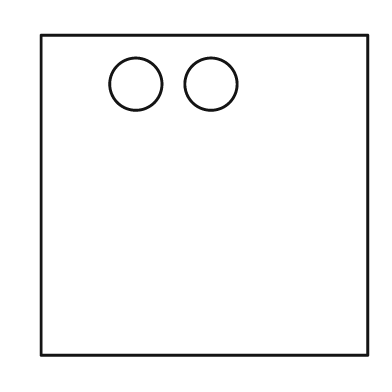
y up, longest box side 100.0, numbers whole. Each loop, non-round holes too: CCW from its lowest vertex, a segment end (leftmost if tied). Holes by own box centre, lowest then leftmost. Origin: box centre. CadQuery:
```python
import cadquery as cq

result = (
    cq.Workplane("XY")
    .moveTo(-50.0, -49.0)
    .lineTo(50.0, -49.0)
    .lineTo(50.0, 49.0)
    .lineTo(-50.0, 49.0)
    .close()
    .moveTo(-21.0, 34.0)
    .circle(8.0)
    .moveTo(2.0, 34.0)
    .circle(8.0)
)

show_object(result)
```